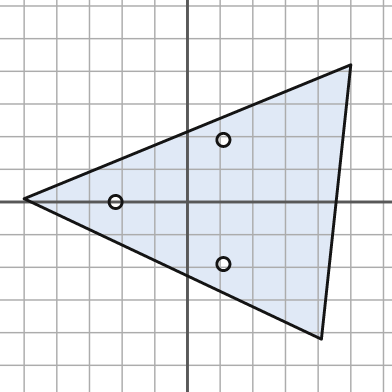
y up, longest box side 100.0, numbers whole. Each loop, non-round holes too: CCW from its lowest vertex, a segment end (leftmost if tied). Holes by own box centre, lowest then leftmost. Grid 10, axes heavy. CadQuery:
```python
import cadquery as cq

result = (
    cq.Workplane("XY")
    .moveTo(41.0, -42.0)
    .lineTo(50.0, 42.0)
    .lineTo(-50.0, 1.0)
    .close()
    .moveTo(11.0, -19.0)
    .circle(2.0)
    .moveTo(-22.0, 0.0)
    .circle(2.0)
    .moveTo(11.0, 19.0)
    .circle(2.0)
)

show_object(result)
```